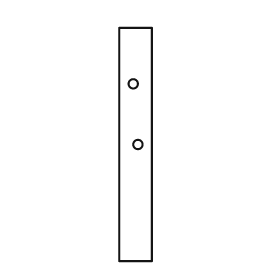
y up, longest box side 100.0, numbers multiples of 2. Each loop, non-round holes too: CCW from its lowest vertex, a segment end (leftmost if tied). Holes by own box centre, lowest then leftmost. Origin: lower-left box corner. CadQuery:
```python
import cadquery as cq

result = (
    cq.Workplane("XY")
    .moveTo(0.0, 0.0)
    .lineTo(14.0, 0.0)
    .lineTo(14.0, 100.0)
    .lineTo(0.0, 100.0)
    .close()
    .moveTo(8.0, 50.0)
    .circle(2.0)
    .moveTo(6.0, 76.0)
    .circle(2.0)
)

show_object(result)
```